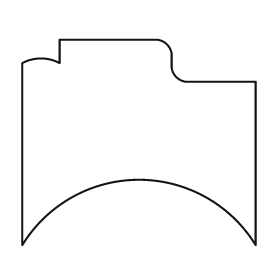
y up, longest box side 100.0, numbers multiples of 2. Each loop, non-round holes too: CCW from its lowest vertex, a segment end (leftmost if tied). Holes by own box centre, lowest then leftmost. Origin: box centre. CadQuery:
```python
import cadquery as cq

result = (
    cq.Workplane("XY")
    .moveTo(-50.0, -44.0)
    .threePointArc((0.0, -16.0), (50.0, -44.0))
    .lineTo(50.0, 26.0)
    .lineTo(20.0, 26.0)
    .threePointArc((16.0, 28.0), (14.0, 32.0))
    .lineTo(14.0, 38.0)
    .threePointArc((12.0, 42.0), (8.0, 44.0))
    .lineTo(-34.0, 44.0)
    .lineTo(-34.0, 34.0)
    .threePointArc((-42.0, 36.0), (-50.0, 34.0))
    .close()
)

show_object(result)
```